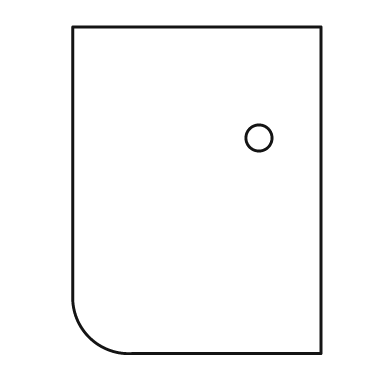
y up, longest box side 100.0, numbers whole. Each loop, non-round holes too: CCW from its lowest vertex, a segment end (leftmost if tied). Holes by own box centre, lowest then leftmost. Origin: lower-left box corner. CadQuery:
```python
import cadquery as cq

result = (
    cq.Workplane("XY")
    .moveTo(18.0, 0.0)
    .lineTo(76.0, 0.0)
    .lineTo(76.0, 100.0)
    .lineTo(0.0, 100.0)
    .lineTo(0.0, 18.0)
    .threePointArc((5.0, 5.0), (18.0, 0.0))
    .close()
    .moveTo(57.0, 66.0)
    .circle(4.0)
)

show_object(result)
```